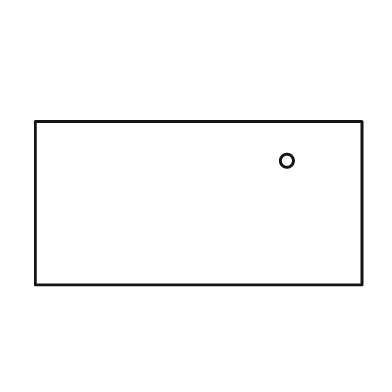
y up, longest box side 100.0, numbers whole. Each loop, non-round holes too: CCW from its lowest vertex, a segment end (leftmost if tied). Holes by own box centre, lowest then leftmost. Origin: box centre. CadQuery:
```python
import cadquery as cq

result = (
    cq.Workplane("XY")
    .moveTo(-50.0, -25.0)
    .lineTo(50.0, -25.0)
    .lineTo(50.0, 25.0)
    .lineTo(-50.0, 25.0)
    .close()
    .moveTo(27.0, 13.0)
    .circle(2.0)
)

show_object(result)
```